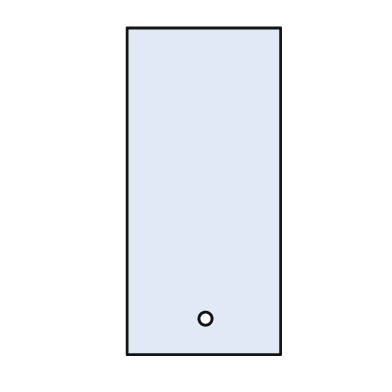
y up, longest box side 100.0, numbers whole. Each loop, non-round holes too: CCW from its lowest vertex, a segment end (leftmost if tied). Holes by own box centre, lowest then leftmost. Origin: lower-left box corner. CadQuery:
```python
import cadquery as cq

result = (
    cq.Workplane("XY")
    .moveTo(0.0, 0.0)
    .lineTo(47.0, 0.0)
    .lineTo(47.0, 100.0)
    .lineTo(0.0, 100.0)
    .close()
    .moveTo(24.0, 11.0)
    .circle(2.0)
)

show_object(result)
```